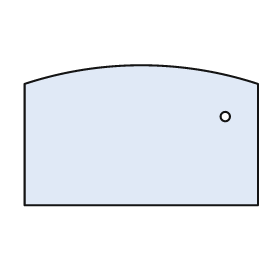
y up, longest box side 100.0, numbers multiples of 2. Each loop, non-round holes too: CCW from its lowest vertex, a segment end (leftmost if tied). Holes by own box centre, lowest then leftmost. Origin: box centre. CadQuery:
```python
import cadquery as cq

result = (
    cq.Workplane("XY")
    .moveTo(-50.0, -30.0)
    .lineTo(50.0, -30.0)
    .lineTo(50.0, 22.0)
    .threePointArc((0.0, 30.0), (-50.0, 22.0))
    .close()
    .moveTo(36.0, 8.0)
    .circle(2.0)
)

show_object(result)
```